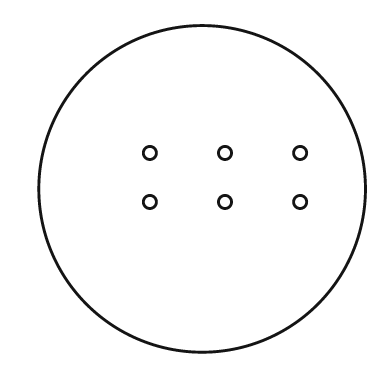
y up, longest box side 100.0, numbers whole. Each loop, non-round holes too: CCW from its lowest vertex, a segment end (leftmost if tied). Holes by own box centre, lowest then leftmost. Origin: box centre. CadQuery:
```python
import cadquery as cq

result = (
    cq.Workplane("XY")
    .moveTo(0.0, 0.0)
    .circle(50.0)
    .moveTo(-16.0, -4.0)
    .circle(2.0)
    .moveTo(7.0, -4.0)
    .circle(2.0)
    .moveTo(30.0, -4.0)
    .circle(2.0)
    .moveTo(-16.0, 11.0)
    .circle(2.0)
    .moveTo(7.0, 11.0)
    .circle(2.0)
    .moveTo(30.0, 11.0)
    .circle(2.0)
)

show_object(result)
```